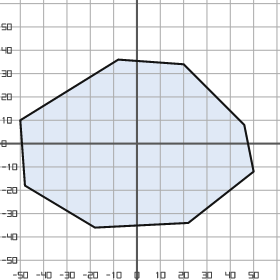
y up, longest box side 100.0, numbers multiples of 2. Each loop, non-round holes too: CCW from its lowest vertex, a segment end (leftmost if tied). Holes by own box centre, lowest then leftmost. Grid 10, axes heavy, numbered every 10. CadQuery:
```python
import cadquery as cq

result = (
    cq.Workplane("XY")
    .moveTo(-18.0, -36.0)
    .lineTo(22.0, -34.0)
    .lineTo(50.0, -12.0)
    .lineTo(46.0, 8.0)
    .lineTo(20.0, 34.0)
    .lineTo(-8.0, 36.0)
    .lineTo(-50.0, 10.0)
    .lineTo(-48.0, -18.0)
    .close()
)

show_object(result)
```